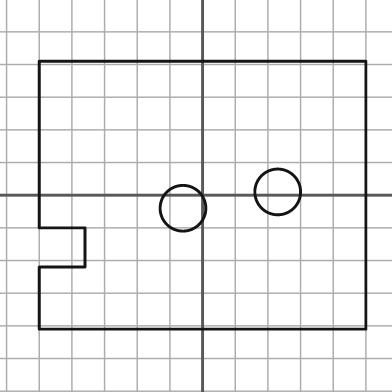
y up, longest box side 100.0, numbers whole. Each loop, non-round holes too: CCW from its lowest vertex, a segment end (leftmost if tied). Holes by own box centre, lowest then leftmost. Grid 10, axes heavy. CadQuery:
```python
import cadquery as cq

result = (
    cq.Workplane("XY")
    .moveTo(-50.0, -41.0)
    .lineTo(50.0, -41.0)
    .lineTo(50.0, 41.0)
    .lineTo(-50.0, 41.0)
    .lineTo(-50.0, -10.0)
    .lineTo(-36.0, -10.0)
    .lineTo(-36.0, -22.0)
    .lineTo(-50.0, -22.0)
    .close()
    .moveTo(-6.0, -4.0)
    .circle(7.0)
    .moveTo(23.0, 1.0)
    .circle(7.0)
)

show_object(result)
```